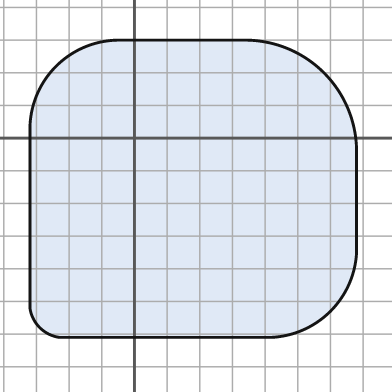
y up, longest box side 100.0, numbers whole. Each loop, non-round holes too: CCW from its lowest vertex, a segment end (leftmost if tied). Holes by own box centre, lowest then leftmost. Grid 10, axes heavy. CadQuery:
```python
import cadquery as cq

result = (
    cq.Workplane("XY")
    .moveTo(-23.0, -61.0)
    .lineTo(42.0, -61.0)
    .threePointArc((60.0, -53.0), (68.0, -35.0))
    .lineTo(68.0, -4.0)
    .threePointArc((58.0, 20.0), (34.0, 30.0))
    .lineTo(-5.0, 30.0)
    .threePointArc((-24.0, 22.0), (-32.0, 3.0))
    .lineTo(-32.0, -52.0)
    .threePointArc((-29.0, -58.0), (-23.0, -61.0))
    .close()
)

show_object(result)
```